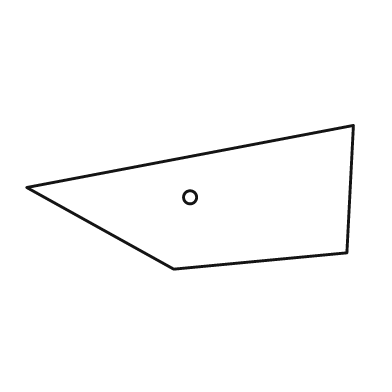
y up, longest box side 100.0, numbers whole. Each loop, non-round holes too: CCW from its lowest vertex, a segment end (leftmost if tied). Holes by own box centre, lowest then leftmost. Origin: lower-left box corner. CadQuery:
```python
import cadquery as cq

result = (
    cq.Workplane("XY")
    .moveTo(45.0, 0.0)
    .lineTo(98.0, 5.0)
    .lineTo(100.0, 44.0)
    .lineTo(0.0, 25.0)
    .close()
    .moveTo(50.0, 22.0)
    .circle(2.0)
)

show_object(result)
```